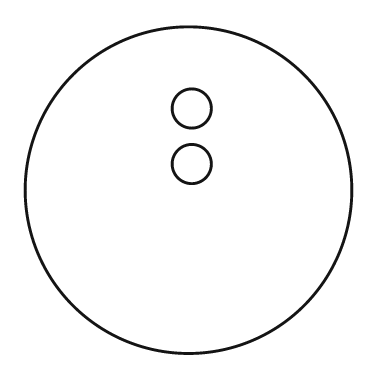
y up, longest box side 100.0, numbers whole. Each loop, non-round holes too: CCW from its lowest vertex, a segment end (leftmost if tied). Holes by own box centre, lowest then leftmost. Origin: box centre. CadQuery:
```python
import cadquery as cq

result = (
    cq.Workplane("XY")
    .moveTo(0.0, 0.0)
    .circle(50.0)
    .moveTo(1.0, 8.0)
    .circle(6.0)
    .moveTo(1.0, 25.0)
    .circle(6.0)
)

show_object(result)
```